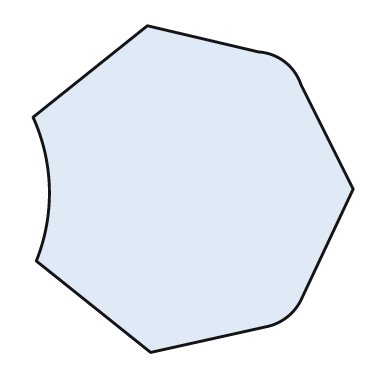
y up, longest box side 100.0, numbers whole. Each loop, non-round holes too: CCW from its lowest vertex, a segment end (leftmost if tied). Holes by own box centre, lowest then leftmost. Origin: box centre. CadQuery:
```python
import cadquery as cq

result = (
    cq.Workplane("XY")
    .moveTo(-13.0, -50.0)
    .lineTo(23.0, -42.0)
    .threePointArc((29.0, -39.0), (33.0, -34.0))
    .lineTo(49.0, 0.0)
    .lineTo(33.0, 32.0)
    .threePointArc((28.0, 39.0), (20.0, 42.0))
    .lineTo(-14.0, 50.0)
    .lineTo(-49.0, 22.0)
    .threePointArc((-44.0, 0.0), (-48.0, -22.0))
    .close()
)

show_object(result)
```